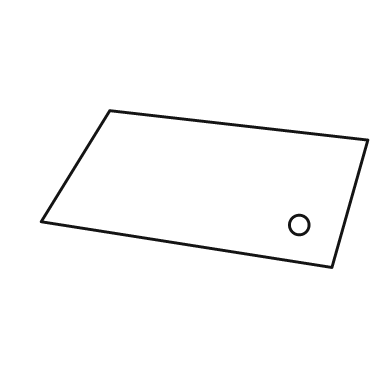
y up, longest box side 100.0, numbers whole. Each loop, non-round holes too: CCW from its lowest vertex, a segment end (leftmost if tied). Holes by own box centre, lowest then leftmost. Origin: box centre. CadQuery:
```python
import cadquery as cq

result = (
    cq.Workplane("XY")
    .moveTo(39.0, -24.0)
    .lineTo(50.0, 15.0)
    .lineTo(-29.0, 24.0)
    .lineTo(-50.0, -10.0)
    .close()
    .moveTo(29.0, -11.0)
    .circle(3.0)
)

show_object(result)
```